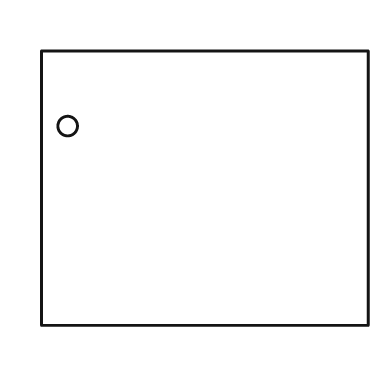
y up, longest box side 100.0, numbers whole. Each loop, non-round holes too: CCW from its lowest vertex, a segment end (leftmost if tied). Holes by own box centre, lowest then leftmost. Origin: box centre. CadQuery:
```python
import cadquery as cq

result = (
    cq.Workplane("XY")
    .moveTo(-50.0, -42.0)
    .lineTo(50.0, -42.0)
    .lineTo(50.0, 42.0)
    .lineTo(-50.0, 42.0)
    .close()
    .moveTo(-42.0, 19.0)
    .circle(3.0)
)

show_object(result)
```